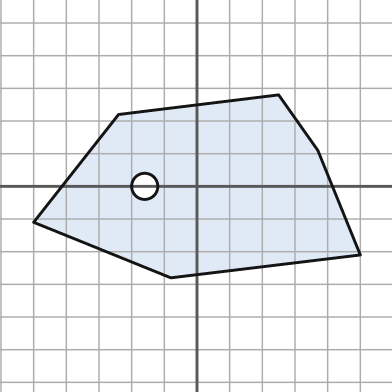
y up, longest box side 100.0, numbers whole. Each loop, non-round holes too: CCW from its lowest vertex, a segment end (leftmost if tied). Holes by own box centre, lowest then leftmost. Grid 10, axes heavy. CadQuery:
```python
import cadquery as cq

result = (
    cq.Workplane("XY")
    .moveTo(-8.0, -28.0)
    .lineTo(50.0, -21.0)
    .lineTo(37.0, 11.0)
    .lineTo(25.0, 28.0)
    .lineTo(-24.0, 22.0)
    .lineTo(-50.0, -11.0)
    .close()
    .moveTo(-16.0, 0.0)
    .circle(4.0)
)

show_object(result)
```